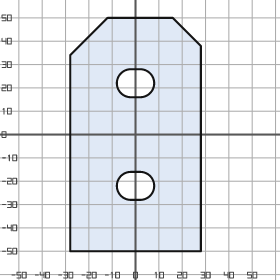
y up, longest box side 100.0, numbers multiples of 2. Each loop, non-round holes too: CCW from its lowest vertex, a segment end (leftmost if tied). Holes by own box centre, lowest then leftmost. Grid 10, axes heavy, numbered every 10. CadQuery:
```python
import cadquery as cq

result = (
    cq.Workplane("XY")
    .moveTo(-28.0, -50.0)
    .lineTo(28.0, -50.0)
    .lineTo(28.0, 38.0)
    .lineTo(16.0, 50.0)
    .lineTo(-12.0, 50.0)
    .lineTo(-28.0, 34.0)
    .close()
    .moveTo(-2.0, -28.0)
    .lineTo(2.0, -28.0)
    .threePointArc((8.0, -22.0), (2.0, -16.0))
    .lineTo(-2.0, -16.0)
    .threePointArc((-8.0, -22.0), (-2.0, -28.0))
    .close()
    .moveTo(-2.0, 16.0)
    .lineTo(2.0, 16.0)
    .threePointArc((8.0, 22.0), (2.0, 28.0))
    .lineTo(-2.0, 28.0)
    .threePointArc((-8.0, 22.0), (-2.0, 16.0))
    .close()
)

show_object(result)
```